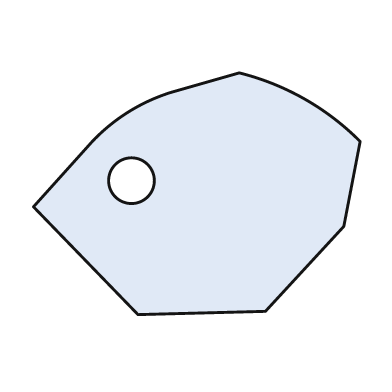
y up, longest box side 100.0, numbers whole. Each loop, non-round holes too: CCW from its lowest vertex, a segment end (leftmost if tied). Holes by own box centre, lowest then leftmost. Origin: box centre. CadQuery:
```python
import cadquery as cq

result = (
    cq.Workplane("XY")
    .moveTo(-18.0, -37.0)
    .lineTo(21.0, -36.0)
    .lineTo(45.0, -10.0)
    .lineTo(50.0, 16.0)
    .threePointArc((33.0, 29.0), (13.0, 37.0))
    .lineTo(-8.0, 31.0)
    .threePointArc((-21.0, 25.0), (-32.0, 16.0))
    .lineTo(-50.0, -4.0)
    .close()
    .moveTo(-20.0, 4.0)
    .circle(7.0)
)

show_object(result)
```